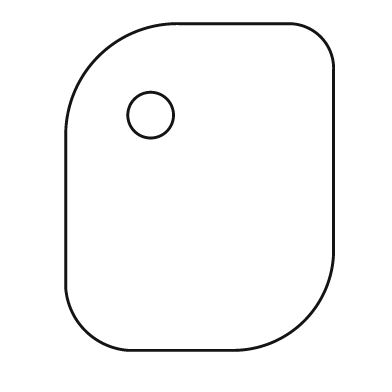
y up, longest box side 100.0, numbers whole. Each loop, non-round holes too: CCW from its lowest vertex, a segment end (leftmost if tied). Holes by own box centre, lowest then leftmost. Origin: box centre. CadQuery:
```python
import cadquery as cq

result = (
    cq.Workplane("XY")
    .moveTo(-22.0, -50.0)
    .lineTo(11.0, -50.0)
    .threePointArc((32.0, -41.0), (41.0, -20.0))
    .lineTo(41.0, 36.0)
    .threePointArc((37.0, 46.0), (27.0, 50.0))
    .lineTo(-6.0, 50.0)
    .threePointArc((-31.0, 40.0), (-41.0, 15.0))
    .lineTo(-41.0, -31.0)
    .threePointArc((-35.0, -44.0), (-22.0, -50.0))
    .close()
    .moveTo(-15.0, 22.0)
    .circle(7.0)
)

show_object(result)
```